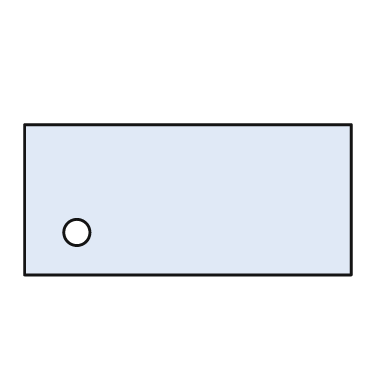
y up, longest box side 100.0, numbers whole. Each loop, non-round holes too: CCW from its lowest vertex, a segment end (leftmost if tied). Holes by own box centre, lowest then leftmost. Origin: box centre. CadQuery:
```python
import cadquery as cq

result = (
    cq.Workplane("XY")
    .moveTo(-50.0, -23.0)
    .lineTo(50.0, -23.0)
    .lineTo(50.0, 23.0)
    .lineTo(-50.0, 23.0)
    .close()
    .moveTo(-34.0, -10.0)
    .circle(4.0)
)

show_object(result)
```